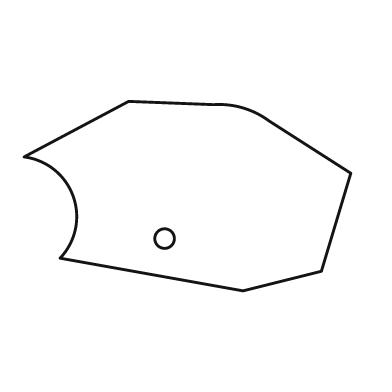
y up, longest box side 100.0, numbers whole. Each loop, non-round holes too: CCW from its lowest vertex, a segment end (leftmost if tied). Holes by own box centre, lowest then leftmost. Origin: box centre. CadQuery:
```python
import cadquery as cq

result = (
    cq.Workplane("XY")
    .moveTo(17.0, -29.0)
    .lineTo(41.0, -23.0)
    .lineTo(50.0, 7.0)
    .lineTo(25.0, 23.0)
    .threePointArc((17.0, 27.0), (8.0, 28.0))
    .lineTo(-18.0, 29.0)
    .lineTo(-50.0, 12.0)
    .threePointArc((-35.0, 0.0), (-39.0, -19.0))
    .close()
    .moveTo(-7.0, -13.0)
    .circle(3.0)
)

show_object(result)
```